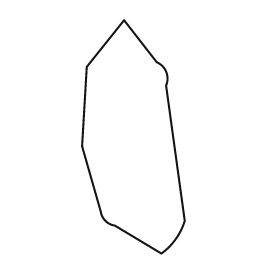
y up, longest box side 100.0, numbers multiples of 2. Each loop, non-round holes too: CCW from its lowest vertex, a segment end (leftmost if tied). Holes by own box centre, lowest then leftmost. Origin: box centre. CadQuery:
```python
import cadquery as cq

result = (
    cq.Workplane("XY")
    .moveTo(12.0, -50.0)
    .threePointArc((18.0, -44.0), (22.0, -36.0))
    .lineTo(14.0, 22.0)
    .threePointArc((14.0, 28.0), (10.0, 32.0))
    .lineTo(-4.0, 50.0)
    .lineTo(-20.0, 30.0)
    .lineTo(-22.0, -4.0)
    .lineTo(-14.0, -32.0)
    .threePointArc((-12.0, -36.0), (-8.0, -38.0))
    .close()
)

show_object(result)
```